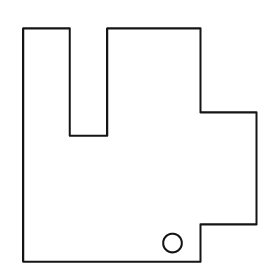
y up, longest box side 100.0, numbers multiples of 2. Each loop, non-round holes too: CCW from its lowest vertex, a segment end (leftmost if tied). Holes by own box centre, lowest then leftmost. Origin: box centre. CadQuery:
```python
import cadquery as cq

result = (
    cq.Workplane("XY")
    .moveTo(-50.0, -50.0)
    .lineTo(26.0, -50.0)
    .lineTo(26.0, -34.0)
    .lineTo(50.0, -34.0)
    .lineTo(50.0, 14.0)
    .lineTo(26.0, 14.0)
    .lineTo(26.0, 50.0)
    .lineTo(-14.0, 50.0)
    .lineTo(-14.0, 4.0)
    .lineTo(-30.0, 4.0)
    .lineTo(-30.0, 50.0)
    .lineTo(-50.0, 50.0)
    .close()
    .moveTo(14.0, -42.0)
    .circle(4.0)
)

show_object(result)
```